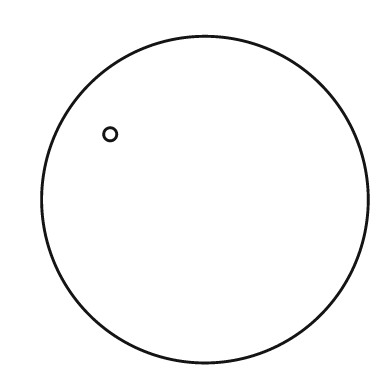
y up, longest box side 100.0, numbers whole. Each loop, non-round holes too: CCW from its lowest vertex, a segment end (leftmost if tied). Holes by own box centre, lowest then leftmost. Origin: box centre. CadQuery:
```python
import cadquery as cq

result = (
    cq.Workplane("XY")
    .moveTo(0.0, 0.0)
    .circle(50.0)
    .moveTo(-29.0, 20.0)
    .circle(2.0)
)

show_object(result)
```